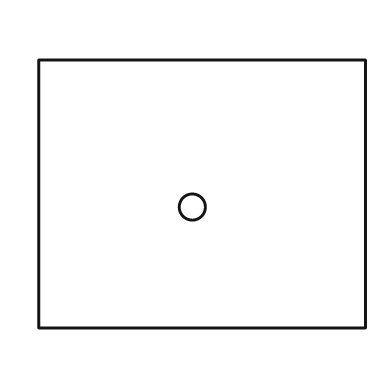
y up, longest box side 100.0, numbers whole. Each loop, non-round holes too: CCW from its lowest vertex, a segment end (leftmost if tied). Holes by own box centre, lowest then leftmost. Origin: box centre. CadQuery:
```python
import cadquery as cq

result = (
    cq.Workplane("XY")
    .moveTo(-50.0, -41.0)
    .lineTo(50.0, -41.0)
    .lineTo(50.0, 41.0)
    .lineTo(-50.0, 41.0)
    .close()
    .moveTo(-3.0, -4.0)
    .circle(4.0)
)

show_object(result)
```